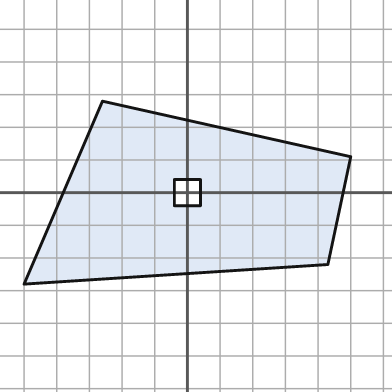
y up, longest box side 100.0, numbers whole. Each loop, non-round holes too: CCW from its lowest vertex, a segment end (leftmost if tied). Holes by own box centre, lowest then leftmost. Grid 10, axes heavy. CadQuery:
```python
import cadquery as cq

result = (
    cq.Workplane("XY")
    .moveTo(-50.0, -28.0)
    .lineTo(43.0, -22.0)
    .lineTo(50.0, 11.0)
    .lineTo(-26.0, 28.0)
    .close()
    .moveTo(-4.0, -4.0)
    .lineTo(4.0, -4.0)
    .lineTo(4.0, 4.0)
    .lineTo(-4.0, 4.0)
    .close()
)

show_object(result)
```